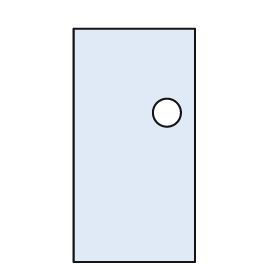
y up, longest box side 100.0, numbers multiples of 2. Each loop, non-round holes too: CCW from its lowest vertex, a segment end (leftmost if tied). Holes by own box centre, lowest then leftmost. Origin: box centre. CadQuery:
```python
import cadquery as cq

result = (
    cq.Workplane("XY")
    .moveTo(-26.0, -50.0)
    .lineTo(26.0, -50.0)
    .lineTo(26.0, 50.0)
    .lineTo(-26.0, 50.0)
    .close()
    .moveTo(14.0, 14.0)
    .circle(6.0)
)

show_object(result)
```